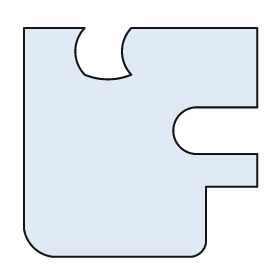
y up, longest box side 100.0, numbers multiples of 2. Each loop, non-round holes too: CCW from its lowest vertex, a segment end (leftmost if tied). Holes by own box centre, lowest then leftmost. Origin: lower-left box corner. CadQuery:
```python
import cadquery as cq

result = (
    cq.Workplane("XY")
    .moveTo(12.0, 0.0)
    .lineTo(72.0, 0.0)
    .threePointArc((76.0, 2.0), (78.0, 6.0))
    .lineTo(78.0, 30.0)
    .lineTo(100.0, 30.0)
    .lineTo(100.0, 44.0)
    .lineTo(74.0, 44.0)
    .threePointArc((64.0, 54.0), (74.0, 64.0))
    .lineTo(100.0, 64.0)
    .lineTo(100.0, 98.0)
    .lineTo(46.0, 98.0)
    .threePointArc((42.0, 88.0), (46.0, 78.0))
    .threePointArc((36.0, 76.0), (26.0, 78.0))
    .threePointArc((22.0, 88.0), (26.0, 98.0))
    .lineTo(0.0, 98.0)
    .lineTo(0.0, 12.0)
    .threePointArc((4.0, 4.0), (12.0, 0.0))
    .close()
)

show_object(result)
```